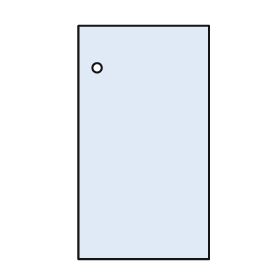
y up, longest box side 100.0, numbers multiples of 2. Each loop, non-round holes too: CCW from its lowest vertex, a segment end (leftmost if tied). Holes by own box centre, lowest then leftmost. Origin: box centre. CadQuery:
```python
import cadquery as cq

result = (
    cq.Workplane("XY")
    .moveTo(-28.0, -50.0)
    .lineTo(28.0, -50.0)
    .lineTo(28.0, 50.0)
    .lineTo(-28.0, 50.0)
    .close()
    .moveTo(-20.0, 32.0)
    .circle(2.0)
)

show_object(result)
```